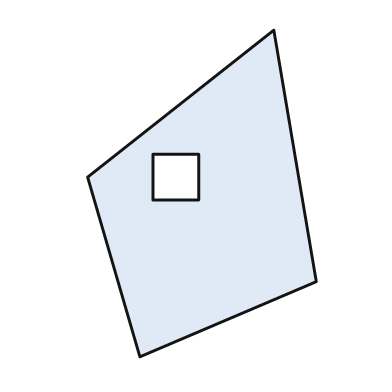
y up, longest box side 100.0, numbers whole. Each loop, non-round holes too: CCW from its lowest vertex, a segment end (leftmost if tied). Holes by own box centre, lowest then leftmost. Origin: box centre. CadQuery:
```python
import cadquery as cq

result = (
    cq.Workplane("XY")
    .moveTo(-19.0, -50.0)
    .lineTo(35.0, -27.0)
    .lineTo(22.0, 50.0)
    .lineTo(-35.0, 5.0)
    .close()
    .moveTo(-15.0, -2.0)
    .lineTo(-1.0, -2.0)
    .lineTo(-1.0, 12.0)
    .lineTo(-15.0, 12.0)
    .close()
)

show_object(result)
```